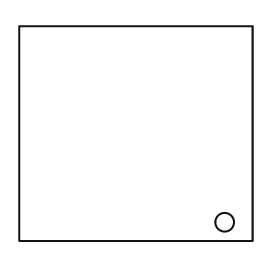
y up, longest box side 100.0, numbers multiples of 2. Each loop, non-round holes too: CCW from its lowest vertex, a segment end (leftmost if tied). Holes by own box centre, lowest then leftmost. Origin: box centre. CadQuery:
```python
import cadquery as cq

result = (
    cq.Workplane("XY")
    .moveTo(-50.0, -46.0)
    .lineTo(50.0, -46.0)
    .lineTo(50.0, 46.0)
    .lineTo(-50.0, 46.0)
    .close()
    .moveTo(38.0, -38.0)
    .circle(4.0)
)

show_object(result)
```